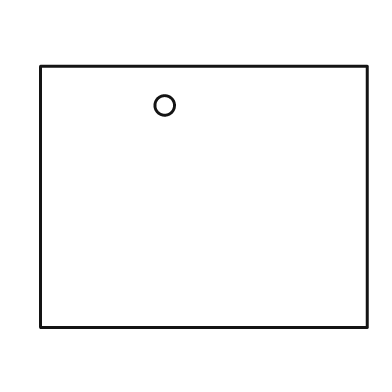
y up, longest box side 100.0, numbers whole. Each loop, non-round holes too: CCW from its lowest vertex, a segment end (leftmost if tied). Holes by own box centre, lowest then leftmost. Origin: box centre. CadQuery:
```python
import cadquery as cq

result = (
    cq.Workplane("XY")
    .moveTo(-50.0, -40.0)
    .lineTo(50.0, -40.0)
    .lineTo(50.0, 40.0)
    .lineTo(-50.0, 40.0)
    .close()
    .moveTo(-12.0, 28.0)
    .circle(3.0)
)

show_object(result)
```